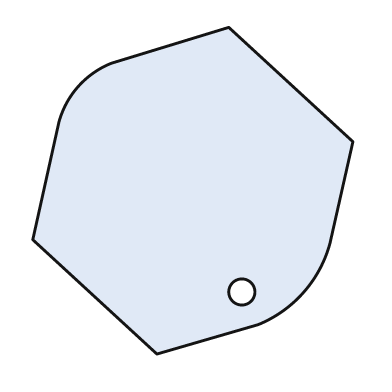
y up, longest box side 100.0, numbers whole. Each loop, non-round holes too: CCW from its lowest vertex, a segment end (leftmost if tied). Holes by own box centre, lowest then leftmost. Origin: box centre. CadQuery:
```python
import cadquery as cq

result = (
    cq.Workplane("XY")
    .moveTo(-11.0, -50.0)
    .lineTo(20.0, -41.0)
    .threePointArc((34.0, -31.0), (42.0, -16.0))
    .lineTo(49.0, 15.0)
    .lineTo(11.0, 50.0)
    .lineTo(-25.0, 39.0)
    .threePointArc((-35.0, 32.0), (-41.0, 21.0))
    .lineTo(-49.0, -15.0)
    .close()
    .moveTo(15.0, -31.0)
    .circle(4.0)
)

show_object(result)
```